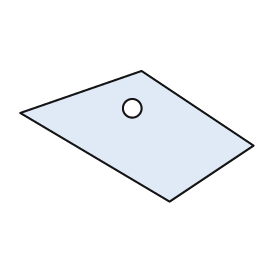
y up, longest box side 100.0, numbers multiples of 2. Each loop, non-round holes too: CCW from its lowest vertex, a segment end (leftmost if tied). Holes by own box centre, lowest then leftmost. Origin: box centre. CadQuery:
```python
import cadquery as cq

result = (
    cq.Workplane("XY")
    .moveTo(14.0, -28.0)
    .lineTo(50.0, -4.0)
    .lineTo(2.0, 28.0)
    .lineTo(-50.0, 10.0)
    .close()
    .moveTo(-2.0, 12.0)
    .circle(4.0)
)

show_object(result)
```